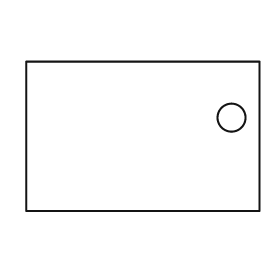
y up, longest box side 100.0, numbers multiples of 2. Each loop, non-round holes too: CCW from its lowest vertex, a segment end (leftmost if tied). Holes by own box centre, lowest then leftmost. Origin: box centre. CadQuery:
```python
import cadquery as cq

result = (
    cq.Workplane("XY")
    .moveTo(-50.0, -32.0)
    .lineTo(50.0, -32.0)
    .lineTo(50.0, 32.0)
    .lineTo(-50.0, 32.0)
    .close()
    .moveTo(38.0, 8.0)
    .circle(6.0)
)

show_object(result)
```